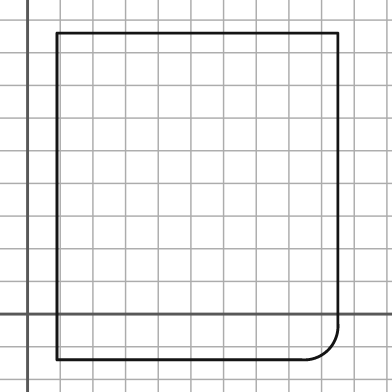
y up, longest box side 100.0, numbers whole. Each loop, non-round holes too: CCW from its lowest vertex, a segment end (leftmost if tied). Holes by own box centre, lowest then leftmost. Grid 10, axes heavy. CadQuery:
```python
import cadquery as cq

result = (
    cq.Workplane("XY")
    .moveTo(9.0, -14.0)
    .lineTo(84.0, -14.0)
    .threePointArc((92.0, -11.0), (95.0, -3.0))
    .lineTo(95.0, 86.0)
    .lineTo(9.0, 86.0)
    .close()
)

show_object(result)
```